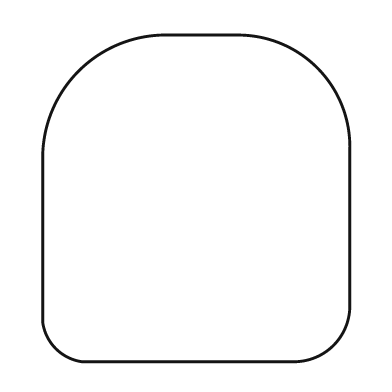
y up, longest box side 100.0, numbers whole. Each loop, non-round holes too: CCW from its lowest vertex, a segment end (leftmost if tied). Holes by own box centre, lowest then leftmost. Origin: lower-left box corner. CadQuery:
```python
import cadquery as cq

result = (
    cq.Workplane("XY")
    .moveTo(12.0, 0.0)
    .lineTo(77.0, 0.0)
    .threePointArc((89.0, 5.0), (94.0, 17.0))
    .lineTo(94.0, 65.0)
    .threePointArc((84.0, 90.0), (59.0, 100.0))
    .lineTo(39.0, 100.0)
    .threePointArc((11.0, 89.0), (0.0, 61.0))
    .lineTo(0.0, 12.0)
    .threePointArc((4.0, 4.0), (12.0, 0.0))
    .close()
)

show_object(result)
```